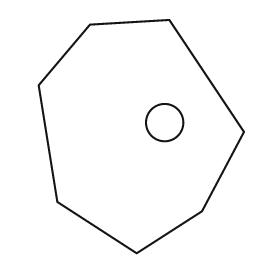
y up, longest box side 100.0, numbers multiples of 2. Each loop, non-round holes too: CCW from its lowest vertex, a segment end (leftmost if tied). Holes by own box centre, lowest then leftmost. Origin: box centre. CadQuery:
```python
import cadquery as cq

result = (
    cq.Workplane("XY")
    .moveTo(-2.0, -50.0)
    .lineTo(26.0, -32.0)
    .lineTo(44.0, 2.0)
    .lineTo(12.0, 50.0)
    .lineTo(-22.0, 48.0)
    .lineTo(-44.0, 22.0)
    .lineTo(-36.0, -28.0)
    .close()
    .moveTo(10.0, 6.0)
    .circle(8.0)
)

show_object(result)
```